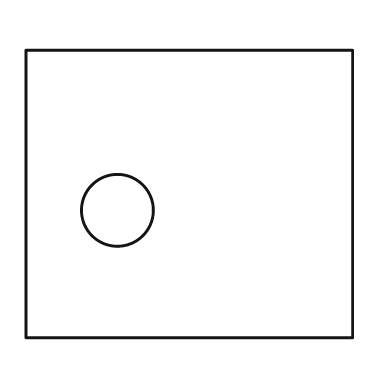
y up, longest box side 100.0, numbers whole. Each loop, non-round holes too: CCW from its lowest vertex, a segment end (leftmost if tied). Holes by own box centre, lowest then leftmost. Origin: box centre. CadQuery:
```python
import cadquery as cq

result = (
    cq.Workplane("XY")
    .moveTo(-50.0, -44.0)
    .lineTo(50.0, -44.0)
    .lineTo(50.0, 44.0)
    .lineTo(-50.0, 44.0)
    .close()
    .moveTo(-22.0, -5.0)
    .circle(11.0)
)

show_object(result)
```